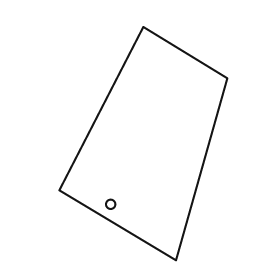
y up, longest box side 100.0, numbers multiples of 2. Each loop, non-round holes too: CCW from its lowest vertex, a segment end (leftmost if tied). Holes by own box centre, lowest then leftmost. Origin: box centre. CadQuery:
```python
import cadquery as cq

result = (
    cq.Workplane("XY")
    .moveTo(14.0, -50.0)
    .lineTo(36.0, 28.0)
    .lineTo(0.0, 50.0)
    .lineTo(-36.0, -20.0)
    .close()
    .moveTo(-14.0, -26.0)
    .circle(2.0)
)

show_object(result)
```